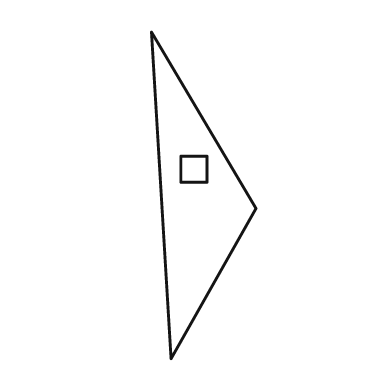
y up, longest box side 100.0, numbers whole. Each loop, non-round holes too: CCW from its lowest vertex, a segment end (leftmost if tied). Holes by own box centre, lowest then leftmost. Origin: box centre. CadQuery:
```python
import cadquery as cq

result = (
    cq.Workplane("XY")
    .moveTo(-10.0, -50.0)
    .lineTo(16.0, -4.0)
    .lineTo(-16.0, 50.0)
    .close()
    .moveTo(-7.0, 4.0)
    .lineTo(1.0, 4.0)
    .lineTo(1.0, 12.0)
    .lineTo(-7.0, 12.0)
    .close()
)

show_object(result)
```